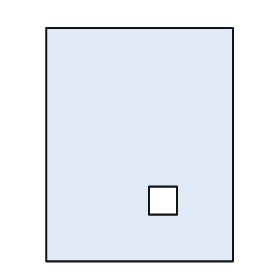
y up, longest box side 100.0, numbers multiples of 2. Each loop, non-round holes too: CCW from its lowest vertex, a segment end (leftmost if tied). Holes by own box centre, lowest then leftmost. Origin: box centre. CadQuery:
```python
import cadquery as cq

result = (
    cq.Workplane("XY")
    .moveTo(-40.0, -50.0)
    .lineTo(40.0, -50.0)
    .lineTo(40.0, 50.0)
    .lineTo(-40.0, 50.0)
    .close()
    .moveTo(4.0, -30.0)
    .lineTo(16.0, -30.0)
    .lineTo(16.0, -18.0)
    .lineTo(4.0, -18.0)
    .close()
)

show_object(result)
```